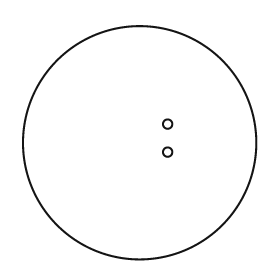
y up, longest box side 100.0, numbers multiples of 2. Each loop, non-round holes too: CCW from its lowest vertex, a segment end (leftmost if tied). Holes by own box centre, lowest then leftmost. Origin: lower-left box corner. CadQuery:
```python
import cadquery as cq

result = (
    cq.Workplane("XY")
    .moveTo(50.0, 50.0)
    .circle(50.0)
    .moveTo(62.0, 46.0)
    .circle(2.0)
    .moveTo(62.0, 58.0)
    .circle(2.0)
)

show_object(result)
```